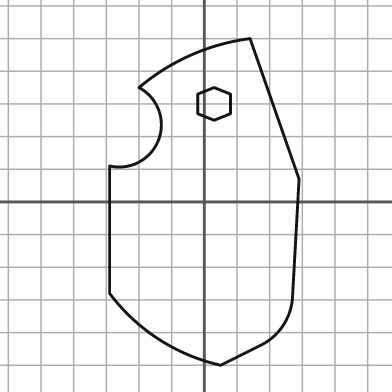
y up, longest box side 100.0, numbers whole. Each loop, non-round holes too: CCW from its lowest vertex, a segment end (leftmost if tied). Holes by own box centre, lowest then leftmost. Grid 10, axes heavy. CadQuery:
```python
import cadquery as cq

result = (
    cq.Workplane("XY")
    .moveTo(5.0, -50.0)
    .lineTo(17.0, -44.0)
    .threePointArc((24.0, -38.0), (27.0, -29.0))
    .lineTo(29.0, 7.0)
    .lineTo(14.0, 50.0)
    .threePointArc((-4.0, 45.0), (-20.0, 35.0))
    .threePointArc((-14.0, 19.0), (-29.0, 11.0))
    .lineTo(-29.0, -28.0)
    .threePointArc((-14.0, -42.0), (5.0, -50.0))
    .close()
    .moveTo(3.0, 25.0)
    .lineTo(8.0, 27.0)
    .lineTo(8.0, 33.0)
    .lineTo(3.0, 35.0)
    .lineTo(-2.0, 33.0)
    .lineTo(-2.0, 27.0)
    .close()
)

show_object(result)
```